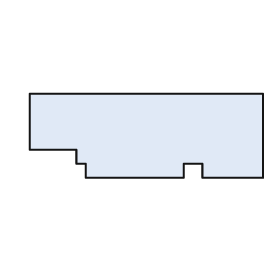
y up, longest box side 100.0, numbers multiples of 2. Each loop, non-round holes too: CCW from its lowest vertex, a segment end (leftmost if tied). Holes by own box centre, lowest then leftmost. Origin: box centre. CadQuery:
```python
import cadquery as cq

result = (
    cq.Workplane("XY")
    .moveTo(-26.0, -18.0)
    .lineTo(16.0, -18.0)
    .lineTo(16.0, -12.0)
    .lineTo(24.0, -12.0)
    .lineTo(24.0, -18.0)
    .lineTo(50.0, -18.0)
    .lineTo(50.0, 18.0)
    .lineTo(-50.0, 18.0)
    .lineTo(-50.0, -6.0)
    .lineTo(-30.0, -6.0)
    .lineTo(-30.0, -12.0)
    .lineTo(-26.0, -12.0)
    .close()
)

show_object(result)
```